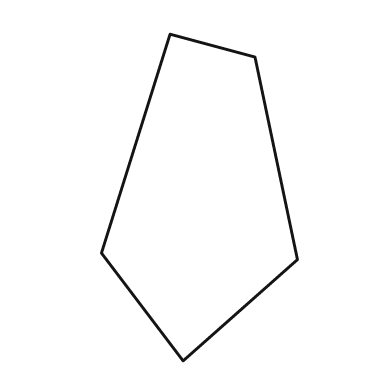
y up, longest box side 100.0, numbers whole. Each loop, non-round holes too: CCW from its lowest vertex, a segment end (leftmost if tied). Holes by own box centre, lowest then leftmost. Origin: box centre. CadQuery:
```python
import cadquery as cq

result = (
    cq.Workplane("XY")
    .moveTo(-5.0, -50.0)
    .lineTo(30.0, -19.0)
    .lineTo(17.0, 43.0)
    .lineTo(-9.0, 50.0)
    .lineTo(-30.0, -17.0)
    .close()
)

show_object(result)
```